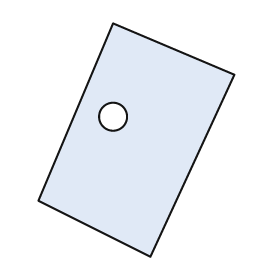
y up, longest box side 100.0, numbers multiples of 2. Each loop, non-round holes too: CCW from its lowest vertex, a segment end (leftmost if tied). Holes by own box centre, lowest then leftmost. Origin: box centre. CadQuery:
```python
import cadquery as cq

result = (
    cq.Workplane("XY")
    .moveTo(6.0, -50.0)
    .lineTo(42.0, 28.0)
    .lineTo(-10.0, 50.0)
    .lineTo(-42.0, -26.0)
    .close()
    .moveTo(-10.0, 10.0)
    .circle(6.0)
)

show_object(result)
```